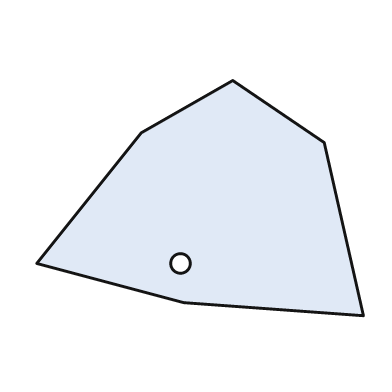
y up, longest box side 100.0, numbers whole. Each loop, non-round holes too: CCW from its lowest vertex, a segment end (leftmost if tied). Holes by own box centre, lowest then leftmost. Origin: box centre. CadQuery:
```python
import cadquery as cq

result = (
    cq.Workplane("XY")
    .moveTo(50.0, -36.0)
    .lineTo(38.0, 17.0)
    .lineTo(10.0, 36.0)
    .lineTo(-18.0, 20.0)
    .lineTo(-50.0, -20.0)
    .lineTo(-5.0, -32.0)
    .close()
    .moveTo(-6.0, -20.0)
    .circle(3.0)
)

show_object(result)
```